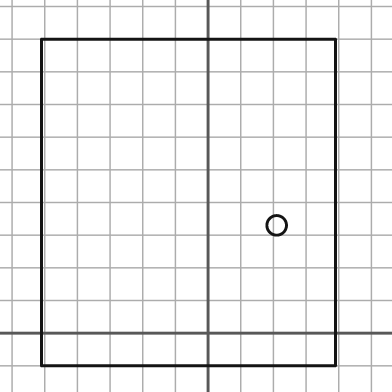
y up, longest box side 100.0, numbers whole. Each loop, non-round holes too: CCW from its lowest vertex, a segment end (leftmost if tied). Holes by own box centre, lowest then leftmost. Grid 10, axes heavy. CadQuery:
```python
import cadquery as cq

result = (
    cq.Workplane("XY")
    .moveTo(-51.0, -10.0)
    .lineTo(39.0, -10.0)
    .lineTo(39.0, 90.0)
    .lineTo(-51.0, 90.0)
    .close()
    .moveTo(21.0, 33.0)
    .circle(3.0)
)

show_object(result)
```